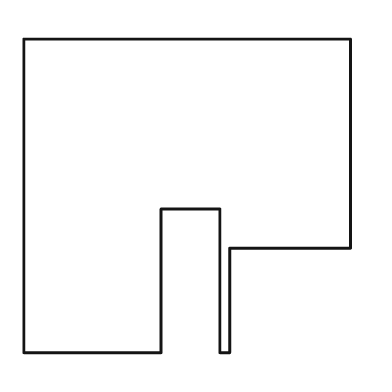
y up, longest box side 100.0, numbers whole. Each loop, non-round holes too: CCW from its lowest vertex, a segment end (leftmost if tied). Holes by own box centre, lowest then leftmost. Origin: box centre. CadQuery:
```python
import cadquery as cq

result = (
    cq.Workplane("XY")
    .moveTo(-50.0, -48.0)
    .lineTo(-8.0, -48.0)
    .lineTo(-8.0, -4.0)
    .lineTo(10.0, -4.0)
    .lineTo(10.0, -48.0)
    .lineTo(13.0, -48.0)
    .lineTo(13.0, -16.0)
    .lineTo(50.0, -16.0)
    .lineTo(50.0, 48.0)
    .lineTo(-50.0, 48.0)
    .close()
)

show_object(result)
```